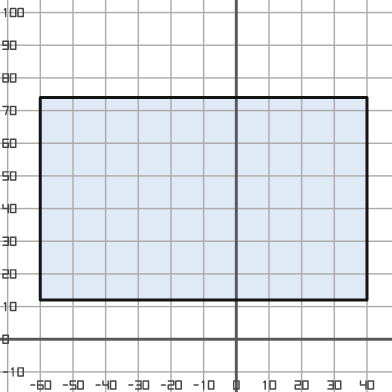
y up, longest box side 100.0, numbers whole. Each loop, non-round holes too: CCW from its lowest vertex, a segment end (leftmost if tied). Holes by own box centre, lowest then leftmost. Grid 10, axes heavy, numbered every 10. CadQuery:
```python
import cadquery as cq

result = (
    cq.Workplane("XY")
    .moveTo(-60.0, 12.0)
    .lineTo(40.0, 12.0)
    .lineTo(40.0, 74.0)
    .lineTo(-60.0, 74.0)
    .close()
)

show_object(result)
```